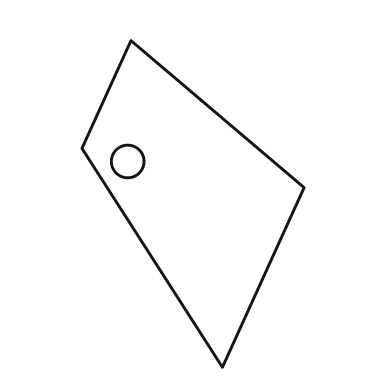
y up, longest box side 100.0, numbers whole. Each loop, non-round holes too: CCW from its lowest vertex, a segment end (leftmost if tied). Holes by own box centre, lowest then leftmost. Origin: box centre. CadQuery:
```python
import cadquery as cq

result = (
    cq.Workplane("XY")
    .moveTo(9.0, -50.0)
    .lineTo(34.0, 5.0)
    .lineTo(-19.0, 50.0)
    .lineTo(-34.0, 17.0)
    .close()
    .moveTo(-20.0, 13.0)
    .circle(5.0)
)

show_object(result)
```